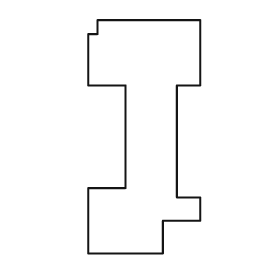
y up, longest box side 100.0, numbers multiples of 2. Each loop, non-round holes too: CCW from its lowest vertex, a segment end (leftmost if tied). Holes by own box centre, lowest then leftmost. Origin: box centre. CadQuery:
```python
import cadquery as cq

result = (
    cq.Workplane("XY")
    .moveTo(-24.0, -50.0)
    .lineTo(8.0, -50.0)
    .lineTo(8.0, -36.0)
    .lineTo(24.0, -36.0)
    .lineTo(24.0, -26.0)
    .lineTo(14.0, -26.0)
    .lineTo(14.0, 22.0)
    .lineTo(24.0, 22.0)
    .lineTo(24.0, 50.0)
    .lineTo(-20.0, 50.0)
    .lineTo(-20.0, 44.0)
    .lineTo(-24.0, 44.0)
    .lineTo(-24.0, 22.0)
    .lineTo(-8.0, 22.0)
    .lineTo(-8.0, -22.0)
    .lineTo(-24.0, -22.0)
    .close()
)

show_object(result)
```